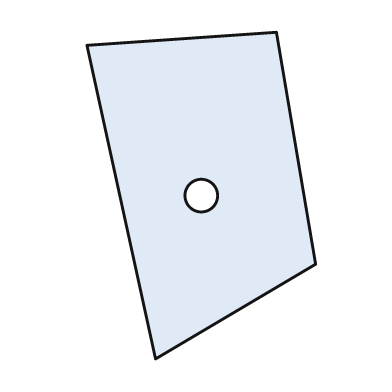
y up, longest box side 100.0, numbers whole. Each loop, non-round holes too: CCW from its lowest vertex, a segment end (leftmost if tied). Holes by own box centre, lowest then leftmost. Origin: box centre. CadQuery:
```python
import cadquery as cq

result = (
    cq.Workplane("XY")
    .moveTo(-14.0, -50.0)
    .lineTo(35.0, -21.0)
    .lineTo(23.0, 50.0)
    .lineTo(-35.0, 46.0)
    .close()
    .moveTo(0.0, 0.0)
    .circle(5.0)
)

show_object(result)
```